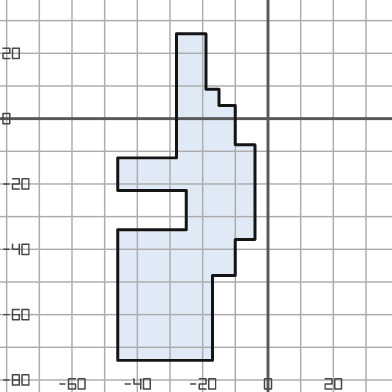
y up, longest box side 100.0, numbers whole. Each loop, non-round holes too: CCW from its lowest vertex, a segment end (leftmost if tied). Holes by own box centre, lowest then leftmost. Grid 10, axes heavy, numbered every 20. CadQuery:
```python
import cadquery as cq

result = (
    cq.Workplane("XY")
    .moveTo(-46.0, -74.0)
    .lineTo(-17.0, -74.0)
    .lineTo(-17.0, -48.0)
    .lineTo(-10.0, -48.0)
    .lineTo(-10.0, -37.0)
    .lineTo(-4.0, -37.0)
    .lineTo(-4.0, -8.0)
    .lineTo(-10.0, -8.0)
    .lineTo(-10.0, 4.0)
    .lineTo(-15.0, 4.0)
    .lineTo(-15.0, 9.0)
    .lineTo(-19.0, 9.0)
    .lineTo(-19.0, 26.0)
    .lineTo(-28.0, 26.0)
    .lineTo(-28.0, -12.0)
    .lineTo(-46.0, -12.0)
    .lineTo(-46.0, -22.0)
    .lineTo(-25.0, -22.0)
    .lineTo(-25.0, -34.0)
    .lineTo(-46.0, -34.0)
    .close()
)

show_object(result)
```